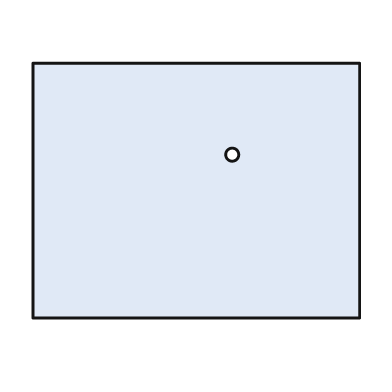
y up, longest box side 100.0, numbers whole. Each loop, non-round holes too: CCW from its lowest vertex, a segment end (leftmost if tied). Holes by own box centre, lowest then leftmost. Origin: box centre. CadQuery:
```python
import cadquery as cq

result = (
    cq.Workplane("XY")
    .moveTo(-50.0, -39.0)
    .lineTo(50.0, -39.0)
    .lineTo(50.0, 39.0)
    .lineTo(-50.0, 39.0)
    .close()
    .moveTo(11.0, 11.0)
    .circle(2.0)
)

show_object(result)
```